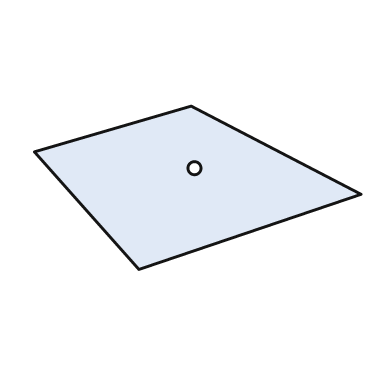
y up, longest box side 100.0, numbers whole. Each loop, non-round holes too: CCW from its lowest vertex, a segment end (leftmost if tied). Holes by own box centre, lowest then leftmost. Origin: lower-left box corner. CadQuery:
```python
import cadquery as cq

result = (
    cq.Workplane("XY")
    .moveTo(32.0, 0.0)
    .lineTo(100.0, 23.0)
    .lineTo(48.0, 50.0)
    .lineTo(0.0, 36.0)
    .close()
    .moveTo(49.0, 31.0)
    .circle(2.0)
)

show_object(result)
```